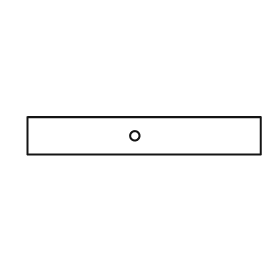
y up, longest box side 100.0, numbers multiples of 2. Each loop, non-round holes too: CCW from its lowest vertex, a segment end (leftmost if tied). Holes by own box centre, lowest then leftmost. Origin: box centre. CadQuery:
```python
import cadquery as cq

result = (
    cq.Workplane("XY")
    .moveTo(-50.0, -8.0)
    .lineTo(50.0, -8.0)
    .lineTo(50.0, 8.0)
    .lineTo(-50.0, 8.0)
    .close()
    .moveTo(-4.0, 0.0)
    .circle(2.0)
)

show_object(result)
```